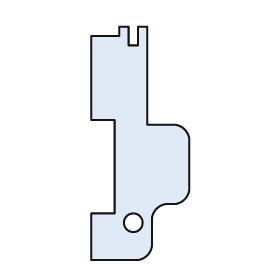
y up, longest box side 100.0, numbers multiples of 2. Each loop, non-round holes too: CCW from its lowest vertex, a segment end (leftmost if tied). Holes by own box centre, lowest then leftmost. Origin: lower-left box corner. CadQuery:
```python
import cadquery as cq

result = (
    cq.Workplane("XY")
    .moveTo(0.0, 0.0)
    .lineTo(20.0, 0.0)
    .threePointArc((24.0, 2.0), (26.0, 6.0))
    .lineTo(26.0, 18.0)
    .threePointArc((28.0, 22.0), (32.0, 24.0))
    .lineTo(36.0, 24.0)
    .threePointArc((40.0, 26.0), (42.0, 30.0))
    .lineTo(42.0, 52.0)
    .threePointArc((40.0, 56.0), (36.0, 58.0))
    .lineTo(24.0, 58.0)
    .lineTo(24.0, 100.0)
    .lineTo(20.0, 100.0)
    .lineTo(20.0, 92.0)
    .lineTo(16.0, 92.0)
    .lineTo(16.0, 100.0)
    .lineTo(12.0, 100.0)
    .lineTo(12.0, 96.0)
    .lineTo(0.0, 96.0)
    .lineTo(0.0, 60.0)
    .lineTo(10.0, 60.0)
    .lineTo(10.0, 20.0)
    .lineTo(0.0, 20.0)
    .close()
    .moveTo(18.0, 16.0)
    .circle(4.0)
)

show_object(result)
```